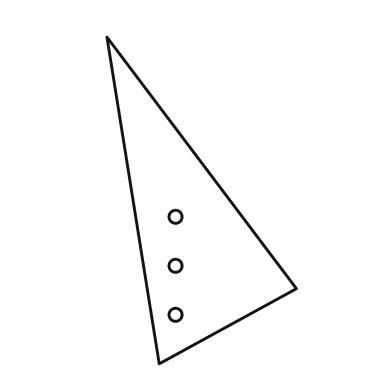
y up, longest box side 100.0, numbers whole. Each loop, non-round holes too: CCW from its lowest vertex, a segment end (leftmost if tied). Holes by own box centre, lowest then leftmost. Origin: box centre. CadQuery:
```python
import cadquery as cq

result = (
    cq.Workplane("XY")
    .moveTo(-13.0, -50.0)
    .lineTo(29.0, -27.0)
    .lineTo(-29.0, 50.0)
    .close()
    .moveTo(-8.0, -35.0)
    .circle(2.0)
    .moveTo(-8.0, -20.0)
    .circle(2.0)
    .moveTo(-8.0, -5.0)
    .circle(2.0)
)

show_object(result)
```